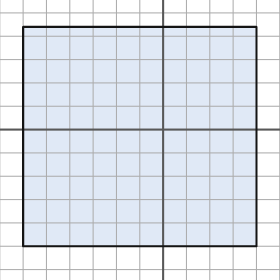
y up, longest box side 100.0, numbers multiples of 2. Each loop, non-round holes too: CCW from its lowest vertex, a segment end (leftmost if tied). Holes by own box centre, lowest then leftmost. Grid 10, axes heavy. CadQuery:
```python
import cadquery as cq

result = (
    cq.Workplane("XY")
    .moveTo(-60.0, -50.0)
    .lineTo(40.0, -50.0)
    .lineTo(40.0, 44.0)
    .lineTo(-60.0, 44.0)
    .close()
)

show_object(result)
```